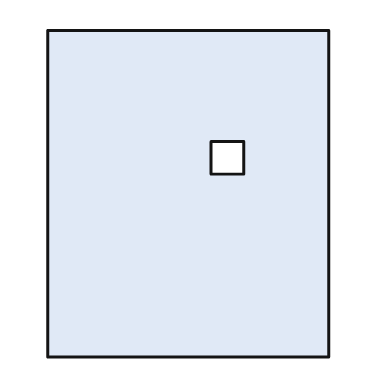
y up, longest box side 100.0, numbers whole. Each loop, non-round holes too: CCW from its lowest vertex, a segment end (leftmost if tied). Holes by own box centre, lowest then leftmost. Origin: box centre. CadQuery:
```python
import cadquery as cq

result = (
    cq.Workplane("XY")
    .moveTo(-43.0, -50.0)
    .lineTo(43.0, -50.0)
    .lineTo(43.0, 50.0)
    .lineTo(-43.0, 50.0)
    .close()
    .moveTo(7.0, 6.0)
    .lineTo(17.0, 6.0)
    .lineTo(17.0, 16.0)
    .lineTo(7.0, 16.0)
    .close()
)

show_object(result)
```